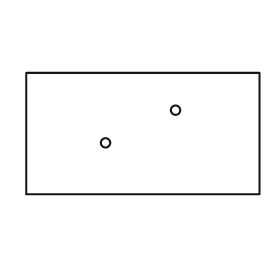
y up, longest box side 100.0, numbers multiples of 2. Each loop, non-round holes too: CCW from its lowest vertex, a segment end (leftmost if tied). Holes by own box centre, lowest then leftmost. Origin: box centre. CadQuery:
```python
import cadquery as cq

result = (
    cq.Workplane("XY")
    .moveTo(-50.0, -26.0)
    .lineTo(50.0, -26.0)
    .lineTo(50.0, 26.0)
    .lineTo(-50.0, 26.0)
    .close()
    .moveTo(-16.0, -4.0)
    .circle(2.0)
    .moveTo(14.0, 10.0)
    .circle(2.0)
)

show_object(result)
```